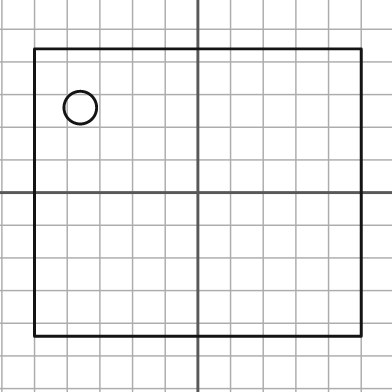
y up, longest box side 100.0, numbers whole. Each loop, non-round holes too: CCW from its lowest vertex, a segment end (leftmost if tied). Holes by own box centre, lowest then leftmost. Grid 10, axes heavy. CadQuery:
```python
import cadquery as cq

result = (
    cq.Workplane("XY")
    .moveTo(-50.0, -44.0)
    .lineTo(50.0, -44.0)
    .lineTo(50.0, 44.0)
    .lineTo(-50.0, 44.0)
    .close()
    .moveTo(-36.0, 26.0)
    .circle(5.0)
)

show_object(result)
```